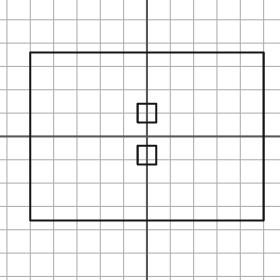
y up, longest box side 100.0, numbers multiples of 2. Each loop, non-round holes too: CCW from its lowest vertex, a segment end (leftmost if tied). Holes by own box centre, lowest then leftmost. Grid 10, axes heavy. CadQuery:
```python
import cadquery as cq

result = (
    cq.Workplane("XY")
    .moveTo(-50.0, -36.0)
    .lineTo(50.0, -36.0)
    .lineTo(50.0, 36.0)
    .lineTo(-50.0, 36.0)
    .close()
    .moveTo(-4.0, -12.0)
    .lineTo(4.0, -12.0)
    .lineTo(4.0, -4.0)
    .lineTo(-4.0, -4.0)
    .close()
    .moveTo(-4.0, 6.0)
    .lineTo(4.0, 6.0)
    .lineTo(4.0, 14.0)
    .lineTo(-4.0, 14.0)
    .close()
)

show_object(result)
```